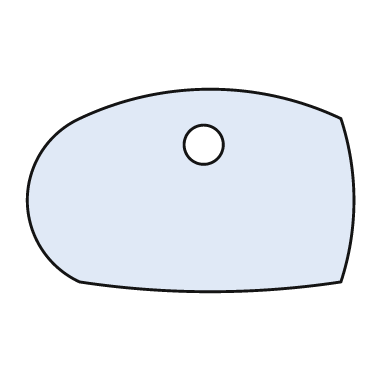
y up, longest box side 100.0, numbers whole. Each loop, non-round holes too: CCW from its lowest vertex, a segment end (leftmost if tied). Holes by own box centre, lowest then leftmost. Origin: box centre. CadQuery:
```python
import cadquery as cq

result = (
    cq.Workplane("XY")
    .moveTo(-34.0, -28.0)
    .threePointArc((6.0, -31.0), (46.0, -28.0))
    .threePointArc((50.0, -3.0), (46.0, 22.0))
    .threePointArc((6.0, 31.0), (-34.0, 22.0))
    .threePointArc((-50.0, -3.0), (-34.0, -28.0))
    .close()
    .moveTo(4.0, 14.0)
    .circle(6.0)
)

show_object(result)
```